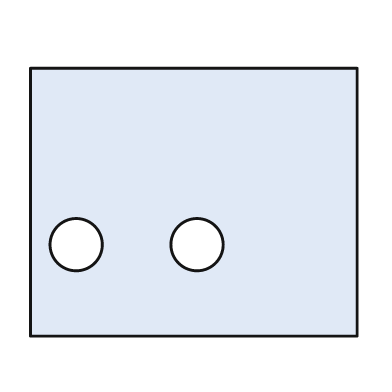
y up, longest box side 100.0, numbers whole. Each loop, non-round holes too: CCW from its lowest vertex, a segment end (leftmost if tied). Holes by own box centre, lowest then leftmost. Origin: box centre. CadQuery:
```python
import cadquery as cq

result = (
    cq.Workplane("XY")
    .moveTo(-50.0, -41.0)
    .lineTo(50.0, -41.0)
    .lineTo(50.0, 41.0)
    .lineTo(-50.0, 41.0)
    .close()
    .moveTo(-36.0, -13.0)
    .circle(8.0)
    .moveTo(1.0, -13.0)
    .circle(8.0)
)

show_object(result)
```